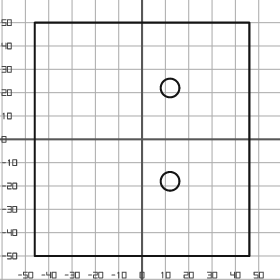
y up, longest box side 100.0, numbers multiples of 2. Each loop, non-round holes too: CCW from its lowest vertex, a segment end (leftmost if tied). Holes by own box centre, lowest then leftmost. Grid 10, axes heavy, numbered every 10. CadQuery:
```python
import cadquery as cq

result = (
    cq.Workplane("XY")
    .moveTo(-46.0, -50.0)
    .lineTo(46.0, -50.0)
    .lineTo(46.0, 50.0)
    .lineTo(-46.0, 50.0)
    .close()
    .moveTo(12.0, -18.0)
    .circle(4.0)
    .moveTo(12.0, 22.0)
    .circle(4.0)
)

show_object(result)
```